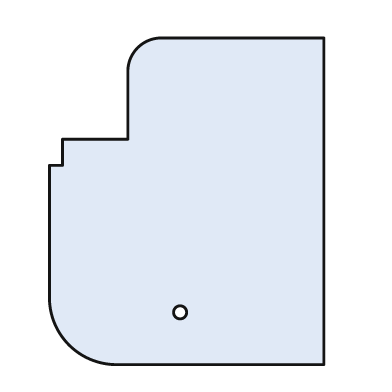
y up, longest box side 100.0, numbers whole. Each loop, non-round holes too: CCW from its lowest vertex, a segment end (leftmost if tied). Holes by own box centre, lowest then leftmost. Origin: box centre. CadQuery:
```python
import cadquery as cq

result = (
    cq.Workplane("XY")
    .moveTo(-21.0, -50.0)
    .lineTo(42.0, -50.0)
    .lineTo(42.0, 50.0)
    .lineTo(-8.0, 50.0)
    .threePointArc((-15.0, 47.0), (-18.0, 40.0))
    .lineTo(-18.0, 19.0)
    .lineTo(-38.0, 19.0)
    .lineTo(-38.0, 11.0)
    .lineTo(-42.0, 11.0)
    .lineTo(-42.0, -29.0)
    .threePointArc((-36.0, -44.0), (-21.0, -50.0))
    .close()
    .moveTo(-2.0, -34.0)
    .circle(2.0)
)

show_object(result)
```